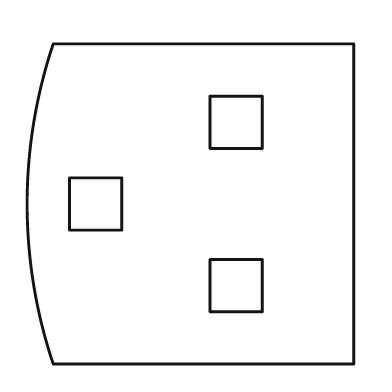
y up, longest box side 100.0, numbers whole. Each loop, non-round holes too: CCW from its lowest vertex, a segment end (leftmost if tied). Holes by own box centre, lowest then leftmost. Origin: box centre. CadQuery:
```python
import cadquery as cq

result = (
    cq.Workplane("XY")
    .moveTo(-42.0, -49.0)
    .lineTo(50.0, -49.0)
    .lineTo(50.0, 49.0)
    .lineTo(-42.0, 49.0)
    .threePointArc((-50.0, 0.0), (-42.0, -49.0))
    .close()
    .moveTo(6.0, -33.0)
    .lineTo(22.0, -33.0)
    .lineTo(22.0, -17.0)
    .lineTo(6.0, -17.0)
    .close()
    .moveTo(-37.0, -8.0)
    .lineTo(-21.0, -8.0)
    .lineTo(-21.0, 8.0)
    .lineTo(-37.0, 8.0)
    .close()
    .moveTo(6.0, 17.0)
    .lineTo(22.0, 17.0)
    .lineTo(22.0, 33.0)
    .lineTo(6.0, 33.0)
    .close()
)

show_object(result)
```